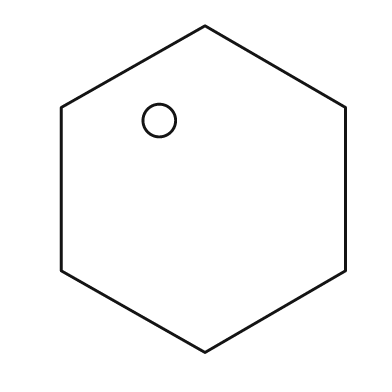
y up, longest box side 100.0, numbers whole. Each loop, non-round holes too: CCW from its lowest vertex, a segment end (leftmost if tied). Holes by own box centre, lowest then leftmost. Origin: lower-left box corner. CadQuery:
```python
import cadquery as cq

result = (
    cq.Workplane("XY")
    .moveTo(44.0, 0.0)
    .lineTo(87.0, 25.0)
    .lineTo(87.0, 75.0)
    .lineTo(44.0, 100.0)
    .lineTo(0.0, 75.0)
    .lineTo(0.0, 25.0)
    .close()
    .moveTo(30.0, 71.0)
    .circle(5.0)
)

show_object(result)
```